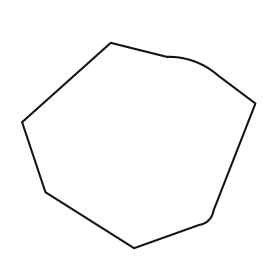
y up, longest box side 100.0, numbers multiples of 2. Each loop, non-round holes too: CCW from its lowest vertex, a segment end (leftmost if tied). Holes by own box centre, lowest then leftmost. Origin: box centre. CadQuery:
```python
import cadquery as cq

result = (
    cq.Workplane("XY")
    .moveTo(-2.0, -44.0)
    .lineTo(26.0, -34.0)
    .threePointArc((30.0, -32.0), (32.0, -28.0))
    .lineTo(50.0, 18.0)
    .lineTo(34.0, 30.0)
    .threePointArc((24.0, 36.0), (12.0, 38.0))
    .lineTo(-12.0, 44.0)
    .lineTo(-50.0, 10.0)
    .lineTo(-40.0, -20.0)
    .close()
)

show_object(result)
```